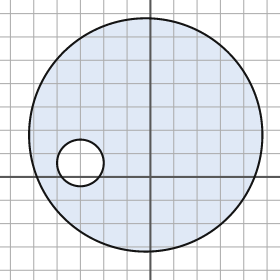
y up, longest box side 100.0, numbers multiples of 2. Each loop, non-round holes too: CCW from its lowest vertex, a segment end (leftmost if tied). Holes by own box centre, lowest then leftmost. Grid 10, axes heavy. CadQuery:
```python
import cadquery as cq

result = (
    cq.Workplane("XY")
    .moveTo(-2.0, 18.0)
    .circle(50.0)
    .moveTo(-30.0, 6.0)
    .circle(10.0)
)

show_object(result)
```